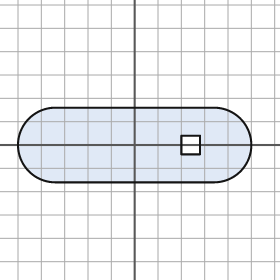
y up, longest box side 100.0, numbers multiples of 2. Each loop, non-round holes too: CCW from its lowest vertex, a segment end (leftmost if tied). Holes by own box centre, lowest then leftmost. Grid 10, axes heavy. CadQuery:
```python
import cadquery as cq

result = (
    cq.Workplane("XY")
    .moveTo(-34.0, -16.0)
    .lineTo(34.0, -16.0)
    .threePointArc((50.0, 0.0), (34.0, 16.0))
    .lineTo(-34.0, 16.0)
    .threePointArc((-50.0, 0.0), (-34.0, -16.0))
    .close()
    .moveTo(20.0, -4.0)
    .lineTo(28.0, -4.0)
    .lineTo(28.0, 4.0)
    .lineTo(20.0, 4.0)
    .close()
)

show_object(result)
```